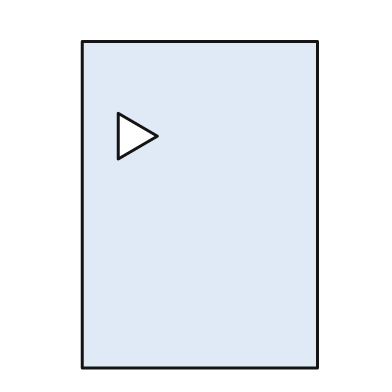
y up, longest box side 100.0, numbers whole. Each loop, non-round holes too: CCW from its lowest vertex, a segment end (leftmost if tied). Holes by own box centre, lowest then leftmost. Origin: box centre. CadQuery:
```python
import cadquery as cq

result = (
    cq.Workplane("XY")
    .moveTo(-36.0, -50.0)
    .lineTo(36.0, -50.0)
    .lineTo(36.0, 50.0)
    .lineTo(-36.0, 50.0)
    .close()
    .moveTo(-25.0, 14.0)
    .lineTo(-13.0, 21.0)
    .lineTo(-25.0, 28.0)
    .close()
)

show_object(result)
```